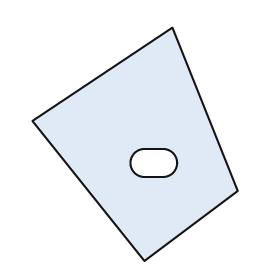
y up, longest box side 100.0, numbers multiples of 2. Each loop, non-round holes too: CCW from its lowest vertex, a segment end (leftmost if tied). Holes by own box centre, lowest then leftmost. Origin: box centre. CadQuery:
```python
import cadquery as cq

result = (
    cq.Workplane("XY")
    .moveTo(4.0, -50.0)
    .lineTo(44.0, -20.0)
    .lineTo(16.0, 50.0)
    .lineTo(-44.0, 10.0)
    .close()
    .moveTo(4.0, -14.0)
    .lineTo(12.0, -14.0)
    .threePointArc((18.0, -8.0), (12.0, -2.0))
    .lineTo(4.0, -2.0)
    .threePointArc((-2.0, -8.0), (4.0, -14.0))
    .close()
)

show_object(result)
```